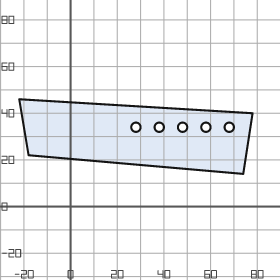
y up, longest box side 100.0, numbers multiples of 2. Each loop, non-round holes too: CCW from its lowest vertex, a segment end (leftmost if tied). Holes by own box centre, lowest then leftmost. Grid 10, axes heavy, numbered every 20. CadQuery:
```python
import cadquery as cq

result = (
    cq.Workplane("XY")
    .moveTo(74.0, 14.0)
    .lineTo(78.0, 40.0)
    .lineTo(-22.0, 46.0)
    .lineTo(-18.0, 22.0)
    .close()
    .moveTo(28.0, 34.0)
    .circle(2.0)
    .moveTo(38.0, 34.0)
    .circle(2.0)
    .moveTo(48.0, 34.0)
    .circle(2.0)
    .moveTo(58.0, 34.0)
    .circle(2.0)
    .moveTo(68.0, 34.0)
    .circle(2.0)
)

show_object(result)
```